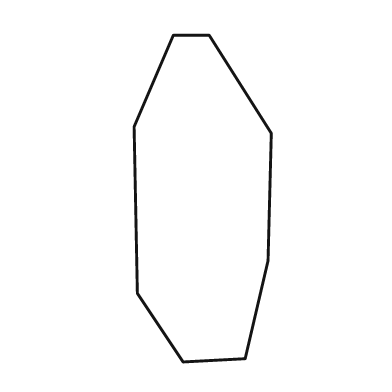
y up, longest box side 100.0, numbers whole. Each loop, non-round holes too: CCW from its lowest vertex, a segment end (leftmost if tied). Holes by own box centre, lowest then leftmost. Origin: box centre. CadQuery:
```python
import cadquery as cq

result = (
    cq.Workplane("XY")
    .moveTo(-6.0, -50.0)
    .lineTo(13.0, -49.0)
    .lineTo(20.0, -19.0)
    .lineTo(21.0, 20.0)
    .lineTo(2.0, 50.0)
    .lineTo(-9.0, 50.0)
    .lineTo(-21.0, 22.0)
    .lineTo(-20.0, -29.0)
    .close()
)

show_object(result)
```